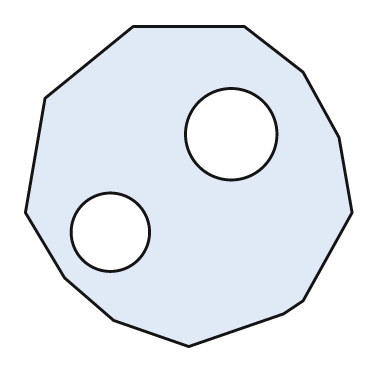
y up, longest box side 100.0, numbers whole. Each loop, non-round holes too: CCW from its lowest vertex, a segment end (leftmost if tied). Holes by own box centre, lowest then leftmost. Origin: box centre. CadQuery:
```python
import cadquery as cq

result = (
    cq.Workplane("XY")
    .moveTo(0.0, -49.0)
    .lineTo(29.0, -39.0)
    .lineTo(35.0, -35.0)
    .lineTo(50.0, -8.0)
    .lineTo(46.0, 15.0)
    .lineTo(35.0, 35.0)
    .lineTo(17.0, 49.0)
    .lineTo(-17.0, 49.0)
    .lineTo(-44.0, 27.0)
    .lineTo(-50.0, -8.0)
    .lineTo(-38.0, -28.0)
    .lineTo(-23.0, -41.0)
    .close()
    .moveTo(-24.0, -14.0)
    .circle(12.0)
    .moveTo(13.0, 16.0)
    .circle(14.0)
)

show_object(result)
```